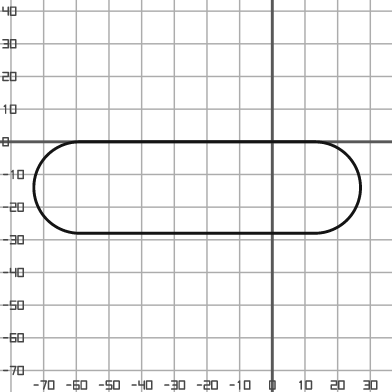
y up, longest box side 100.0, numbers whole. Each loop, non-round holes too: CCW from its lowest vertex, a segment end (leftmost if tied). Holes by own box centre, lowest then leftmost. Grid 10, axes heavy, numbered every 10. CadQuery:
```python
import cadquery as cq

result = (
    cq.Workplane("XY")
    .moveTo(-59.0, -28.0)
    .lineTo(13.0, -28.0)
    .threePointArc((27.0, -14.0), (13.0, 0.0))
    .lineTo(-59.0, 0.0)
    .threePointArc((-73.0, -14.0), (-59.0, -28.0))
    .close()
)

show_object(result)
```